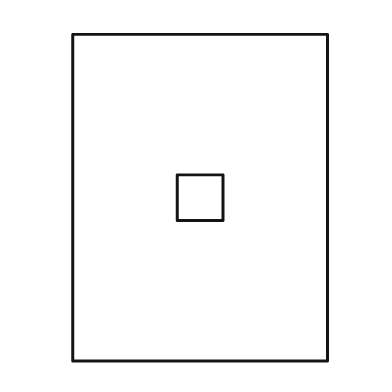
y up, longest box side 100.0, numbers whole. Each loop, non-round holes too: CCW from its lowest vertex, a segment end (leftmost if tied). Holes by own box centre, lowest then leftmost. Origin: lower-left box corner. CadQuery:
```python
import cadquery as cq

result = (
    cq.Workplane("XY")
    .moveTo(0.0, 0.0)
    .lineTo(78.0, 0.0)
    .lineTo(78.0, 100.0)
    .lineTo(0.0, 100.0)
    .close()
    .moveTo(32.0, 43.0)
    .lineTo(46.0, 43.0)
    .lineTo(46.0, 57.0)
    .lineTo(32.0, 57.0)
    .close()
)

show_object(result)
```